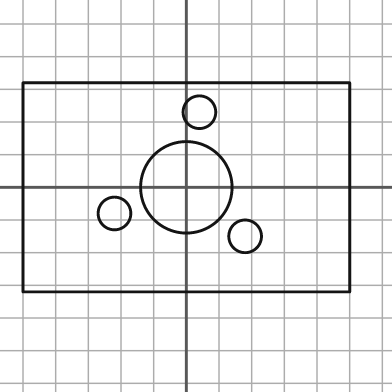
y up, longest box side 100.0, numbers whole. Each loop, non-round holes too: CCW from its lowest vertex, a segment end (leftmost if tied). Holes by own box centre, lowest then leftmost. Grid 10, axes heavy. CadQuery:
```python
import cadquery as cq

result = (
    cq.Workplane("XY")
    .moveTo(-50.0, -32.0)
    .lineTo(50.0, -32.0)
    .lineTo(50.0, 32.0)
    .lineTo(-50.0, 32.0)
    .close()
    .moveTo(18.0, -15.0)
    .circle(5.0)
    .moveTo(-22.0, -8.0)
    .circle(5.0)
    .moveTo(0.0, 0.0)
    .circle(14.0)
    .moveTo(4.0, 23.0)
    .circle(5.0)
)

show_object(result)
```